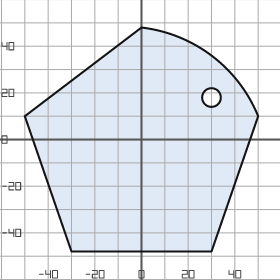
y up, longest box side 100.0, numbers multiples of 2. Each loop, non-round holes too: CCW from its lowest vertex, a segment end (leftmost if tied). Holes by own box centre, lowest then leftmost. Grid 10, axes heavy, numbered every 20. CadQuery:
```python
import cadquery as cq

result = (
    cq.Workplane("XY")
    .moveTo(-30.0, -48.0)
    .lineTo(30.0, -48.0)
    .lineTo(50.0, 10.0)
    .threePointArc((30.0, 36.0), (0.0, 48.0))
    .lineTo(-50.0, 10.0)
    .close()
    .moveTo(30.0, 18.0)
    .circle(4.0)
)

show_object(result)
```